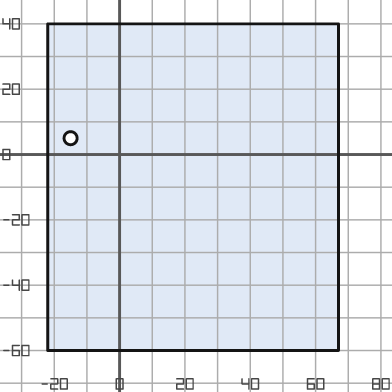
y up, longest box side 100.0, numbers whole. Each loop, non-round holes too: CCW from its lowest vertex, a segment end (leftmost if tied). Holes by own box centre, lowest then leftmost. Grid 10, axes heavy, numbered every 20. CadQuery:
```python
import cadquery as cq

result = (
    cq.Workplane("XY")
    .moveTo(-22.0, -60.0)
    .lineTo(67.0, -60.0)
    .lineTo(67.0, 40.0)
    .lineTo(-22.0, 40.0)
    .close()
    .moveTo(-15.0, 5.0)
    .circle(2.0)
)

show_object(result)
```